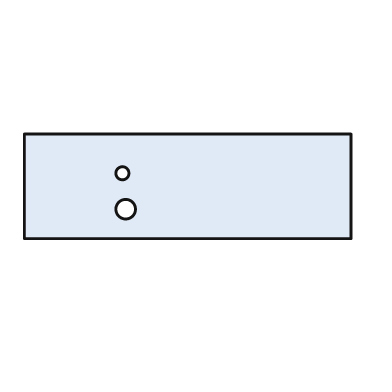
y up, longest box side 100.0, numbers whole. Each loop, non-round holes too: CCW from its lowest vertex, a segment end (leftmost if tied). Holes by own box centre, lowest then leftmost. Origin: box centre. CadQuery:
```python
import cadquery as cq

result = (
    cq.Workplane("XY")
    .moveTo(-50.0, -16.0)
    .lineTo(50.0, -16.0)
    .lineTo(50.0, 16.0)
    .lineTo(-50.0, 16.0)
    .close()
    .moveTo(-19.0, -7.0)
    .circle(3.0)
    .moveTo(-20.0, 4.0)
    .circle(2.0)
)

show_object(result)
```